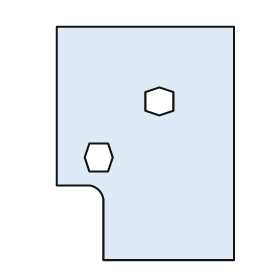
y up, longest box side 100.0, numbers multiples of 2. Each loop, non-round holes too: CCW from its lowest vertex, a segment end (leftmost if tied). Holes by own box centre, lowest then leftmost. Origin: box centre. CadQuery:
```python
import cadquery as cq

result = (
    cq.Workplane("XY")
    .moveTo(-18.0, -50.0)
    .lineTo(38.0, -50.0)
    .lineTo(38.0, 50.0)
    .lineTo(-38.0, 50.0)
    .lineTo(-38.0, -18.0)
    .lineTo(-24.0, -18.0)
    .threePointArc((-20.0, -20.0), (-18.0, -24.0))
    .close()
    .moveTo(-24.0, -12.0)
    .lineTo(-16.0, -12.0)
    .lineTo(-14.0, -6.0)
    .lineTo(-16.0, 0.0)
    .lineTo(-24.0, 0.0)
    .lineTo(-26.0, -6.0)
    .close()
    .moveTo(6.0, 12.0)
    .lineTo(12.0, 14.0)
    .lineTo(12.0, 22.0)
    .lineTo(6.0, 24.0)
    .lineTo(0.0, 22.0)
    .lineTo(0.0, 14.0)
    .close()
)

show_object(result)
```